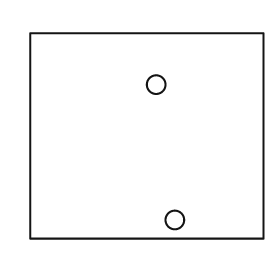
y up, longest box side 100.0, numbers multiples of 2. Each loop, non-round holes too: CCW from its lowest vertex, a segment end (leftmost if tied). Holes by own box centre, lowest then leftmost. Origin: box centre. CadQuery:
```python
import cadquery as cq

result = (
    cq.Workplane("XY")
    .moveTo(-50.0, -44.0)
    .lineTo(50.0, -44.0)
    .lineTo(50.0, 44.0)
    .lineTo(-50.0, 44.0)
    .close()
    .moveTo(12.0, -36.0)
    .circle(4.0)
    .moveTo(4.0, 22.0)
    .circle(4.0)
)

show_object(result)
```